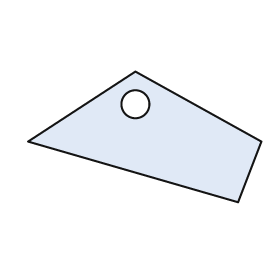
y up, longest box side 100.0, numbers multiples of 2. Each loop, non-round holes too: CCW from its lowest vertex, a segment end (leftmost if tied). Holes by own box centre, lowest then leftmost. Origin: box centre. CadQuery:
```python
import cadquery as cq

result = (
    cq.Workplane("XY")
    .moveTo(40.0, -28.0)
    .lineTo(50.0, -2.0)
    .lineTo(-4.0, 28.0)
    .lineTo(-50.0, -2.0)
    .close()
    .moveTo(-4.0, 14.0)
    .circle(6.0)
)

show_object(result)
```